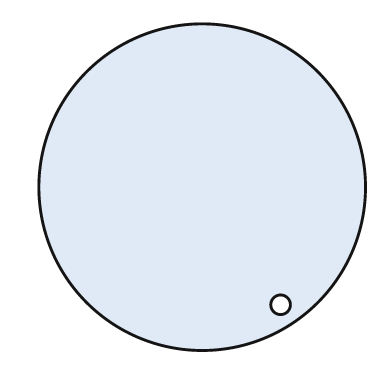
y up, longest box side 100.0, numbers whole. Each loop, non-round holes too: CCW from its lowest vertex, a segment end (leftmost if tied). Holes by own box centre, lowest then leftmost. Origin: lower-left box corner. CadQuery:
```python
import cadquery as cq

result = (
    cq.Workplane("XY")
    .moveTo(50.0, 50.0)
    .circle(50.0)
    .moveTo(74.0, 14.0)
    .circle(3.0)
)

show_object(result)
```